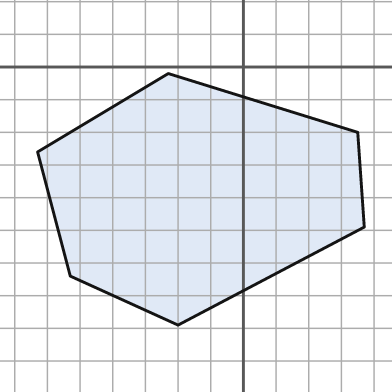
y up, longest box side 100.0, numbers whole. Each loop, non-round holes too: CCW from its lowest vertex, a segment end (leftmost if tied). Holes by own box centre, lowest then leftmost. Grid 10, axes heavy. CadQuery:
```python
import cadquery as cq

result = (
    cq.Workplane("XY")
    .moveTo(-20.0, -79.0)
    .lineTo(37.0, -49.0)
    .lineTo(35.0, -20.0)
    .lineTo(-23.0, -2.0)
    .lineTo(-63.0, -26.0)
    .lineTo(-53.0, -64.0)
    .close()
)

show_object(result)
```